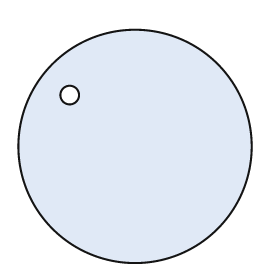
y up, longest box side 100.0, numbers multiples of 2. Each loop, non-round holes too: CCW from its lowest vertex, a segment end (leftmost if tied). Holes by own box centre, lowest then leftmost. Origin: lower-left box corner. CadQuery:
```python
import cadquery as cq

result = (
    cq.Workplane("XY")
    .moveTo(50.0, 50.0)
    .circle(50.0)
    .moveTo(22.0, 72.0)
    .circle(4.0)
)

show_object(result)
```